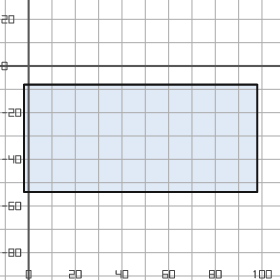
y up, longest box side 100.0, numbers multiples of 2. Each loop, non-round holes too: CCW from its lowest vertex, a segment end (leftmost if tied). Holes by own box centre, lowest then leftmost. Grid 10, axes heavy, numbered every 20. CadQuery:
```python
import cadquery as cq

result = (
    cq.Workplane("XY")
    .moveTo(-2.0, -54.0)
    .lineTo(98.0, -54.0)
    .lineTo(98.0, -8.0)
    .lineTo(-2.0, -8.0)
    .close()
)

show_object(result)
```